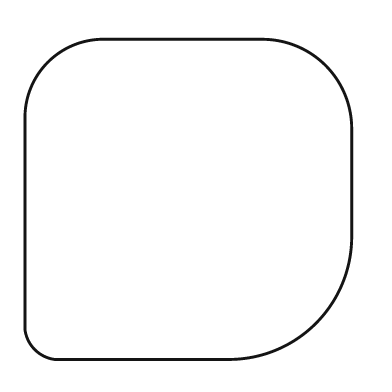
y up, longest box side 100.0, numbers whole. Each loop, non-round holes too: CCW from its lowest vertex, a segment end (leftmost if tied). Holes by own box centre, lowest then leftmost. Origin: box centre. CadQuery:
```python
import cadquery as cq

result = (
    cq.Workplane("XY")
    .moveTo(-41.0, -49.0)
    .lineTo(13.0, -49.0)
    .threePointArc((39.0, -38.0), (50.0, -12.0))
    .lineTo(50.0, 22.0)
    .threePointArc((42.0, 41.0), (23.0, 49.0))
    .lineTo(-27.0, 49.0)
    .threePointArc((-43.0, 42.0), (-50.0, 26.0))
    .lineTo(-50.0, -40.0)
    .threePointArc((-47.0, -46.0), (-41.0, -49.0))
    .close()
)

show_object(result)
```